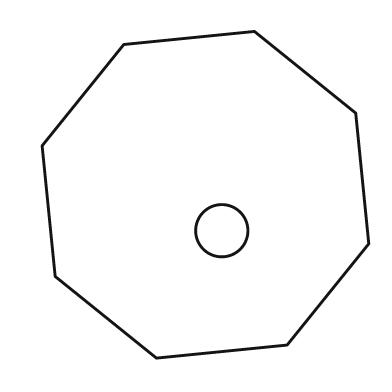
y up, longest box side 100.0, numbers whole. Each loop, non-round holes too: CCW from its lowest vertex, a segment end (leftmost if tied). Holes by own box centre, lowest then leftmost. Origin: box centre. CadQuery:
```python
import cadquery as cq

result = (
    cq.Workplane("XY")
    .moveTo(-15.0, -50.0)
    .lineTo(25.0, -46.0)
    .lineTo(50.0, -15.0)
    .lineTo(46.0, 25.0)
    .lineTo(15.0, 50.0)
    .lineTo(-25.0, 46.0)
    .lineTo(-50.0, 15.0)
    .lineTo(-46.0, -25.0)
    .close()
    .moveTo(5.0, -11.0)
    .circle(8.0)
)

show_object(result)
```